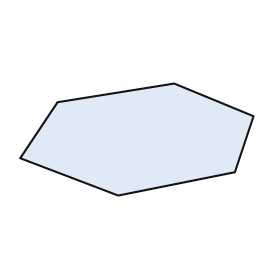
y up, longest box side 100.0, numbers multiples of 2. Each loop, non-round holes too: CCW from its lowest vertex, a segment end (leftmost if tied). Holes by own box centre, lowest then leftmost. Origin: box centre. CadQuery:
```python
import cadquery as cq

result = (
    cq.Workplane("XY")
    .moveTo(-8.0, -24.0)
    .lineTo(42.0, -14.0)
    .lineTo(50.0, 10.0)
    .lineTo(16.0, 24.0)
    .lineTo(-34.0, 16.0)
    .lineTo(-50.0, -8.0)
    .close()
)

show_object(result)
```